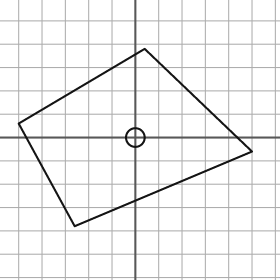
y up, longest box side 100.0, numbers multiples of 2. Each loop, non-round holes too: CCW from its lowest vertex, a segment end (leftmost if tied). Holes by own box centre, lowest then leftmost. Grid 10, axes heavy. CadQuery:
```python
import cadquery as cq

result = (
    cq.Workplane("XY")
    .moveTo(-26.0, -38.0)
    .lineTo(50.0, -6.0)
    .lineTo(4.0, 38.0)
    .lineTo(-50.0, 6.0)
    .close()
    .moveTo(0.0, 0.0)
    .circle(4.0)
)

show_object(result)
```